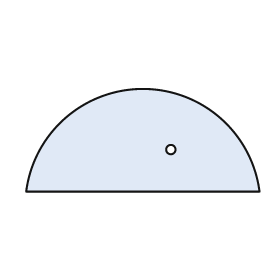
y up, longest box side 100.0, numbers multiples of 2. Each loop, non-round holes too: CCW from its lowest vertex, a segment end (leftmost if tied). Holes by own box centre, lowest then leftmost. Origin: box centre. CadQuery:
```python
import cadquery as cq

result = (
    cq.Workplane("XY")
    .moveTo(-50.0, -22.0)
    .lineTo(50.0, -22.0)
    .threePointArc((0.0, 22.0), (-50.0, -22.0))
    .close()
    .moveTo(12.0, -4.0)
    .circle(2.0)
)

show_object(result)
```